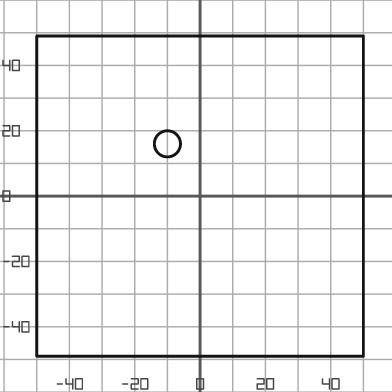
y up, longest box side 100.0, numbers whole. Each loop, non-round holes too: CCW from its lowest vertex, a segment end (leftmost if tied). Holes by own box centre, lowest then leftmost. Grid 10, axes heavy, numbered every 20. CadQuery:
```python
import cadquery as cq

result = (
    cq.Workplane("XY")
    .moveTo(-50.0, -49.0)
    .lineTo(50.0, -49.0)
    .lineTo(50.0, 49.0)
    .lineTo(-50.0, 49.0)
    .close()
    .moveTo(-10.0, 16.0)
    .circle(4.0)
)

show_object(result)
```